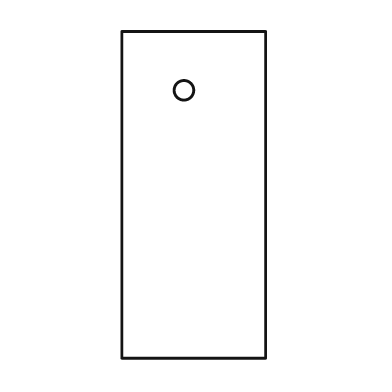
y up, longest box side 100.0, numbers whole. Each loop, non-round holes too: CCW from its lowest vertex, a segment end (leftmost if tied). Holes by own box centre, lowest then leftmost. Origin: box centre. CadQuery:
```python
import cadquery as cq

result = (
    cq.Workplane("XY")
    .moveTo(-22.0, -50.0)
    .lineTo(22.0, -50.0)
    .lineTo(22.0, 50.0)
    .lineTo(-22.0, 50.0)
    .close()
    .moveTo(-3.0, 32.0)
    .circle(3.0)
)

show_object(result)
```